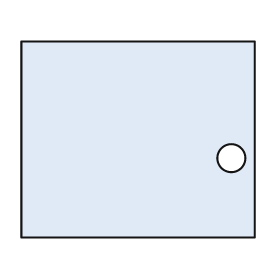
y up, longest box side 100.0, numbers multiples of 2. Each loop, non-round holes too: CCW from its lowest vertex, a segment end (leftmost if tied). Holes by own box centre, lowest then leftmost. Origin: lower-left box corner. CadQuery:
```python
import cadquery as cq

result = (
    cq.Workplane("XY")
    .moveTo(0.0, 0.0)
    .lineTo(100.0, 0.0)
    .lineTo(100.0, 84.0)
    .lineTo(0.0, 84.0)
    .close()
    .moveTo(90.0, 34.0)
    .circle(6.0)
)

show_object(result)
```